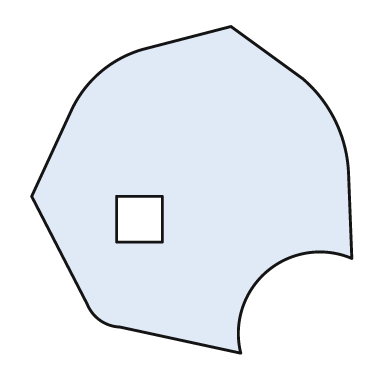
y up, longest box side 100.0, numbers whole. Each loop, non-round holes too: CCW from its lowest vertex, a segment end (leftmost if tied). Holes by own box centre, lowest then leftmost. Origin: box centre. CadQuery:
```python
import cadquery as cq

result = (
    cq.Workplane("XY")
    .moveTo(15.0, -50.0)
    .threePointArc((23.0, -25.0), (49.0, -21.0))
    .lineTo(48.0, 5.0)
    .threePointArc((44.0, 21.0), (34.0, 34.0))
    .lineTo(12.0, 50.0)
    .lineTo(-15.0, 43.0)
    .threePointArc((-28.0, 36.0), (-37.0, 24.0))
    .lineTo(-49.0, -2.0)
    .lineTo(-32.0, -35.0)
    .threePointArc((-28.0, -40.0), (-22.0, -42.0))
    .close()
    .moveTo(-23.0, -16.0)
    .lineTo(-9.0, -16.0)
    .lineTo(-9.0, -2.0)
    .lineTo(-23.0, -2.0)
    .close()
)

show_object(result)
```